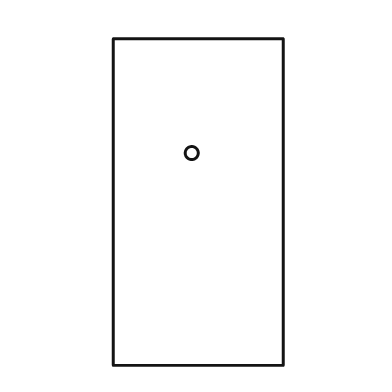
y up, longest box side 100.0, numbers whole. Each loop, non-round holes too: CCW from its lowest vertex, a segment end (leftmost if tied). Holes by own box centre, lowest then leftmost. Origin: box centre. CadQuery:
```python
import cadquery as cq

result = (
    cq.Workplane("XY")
    .moveTo(-26.0, -50.0)
    .lineTo(26.0, -50.0)
    .lineTo(26.0, 50.0)
    .lineTo(-26.0, 50.0)
    .close()
    .moveTo(-2.0, 15.0)
    .circle(2.0)
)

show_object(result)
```